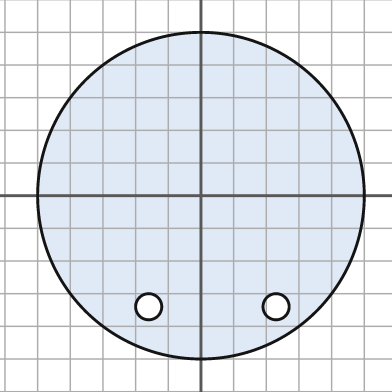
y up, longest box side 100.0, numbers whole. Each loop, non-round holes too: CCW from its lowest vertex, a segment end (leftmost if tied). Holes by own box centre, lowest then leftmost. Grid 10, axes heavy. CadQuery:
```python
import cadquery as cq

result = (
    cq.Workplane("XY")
    .moveTo(0.0, 0.0)
    .circle(50.0)
    .moveTo(-16.0, -34.0)
    .circle(4.0)
    .moveTo(23.0, -34.0)
    .circle(4.0)
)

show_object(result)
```